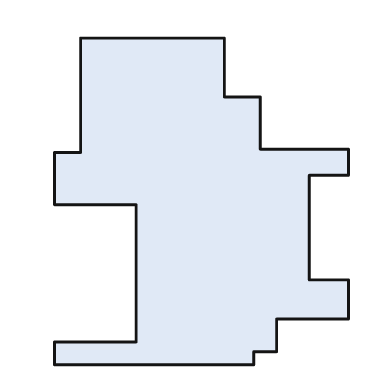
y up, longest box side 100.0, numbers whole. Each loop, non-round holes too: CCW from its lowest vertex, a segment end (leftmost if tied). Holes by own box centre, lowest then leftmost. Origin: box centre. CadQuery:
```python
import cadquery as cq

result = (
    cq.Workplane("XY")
    .moveTo(-45.0, -50.0)
    .lineTo(16.0, -50.0)
    .lineTo(16.0, -46.0)
    .lineTo(23.0, -46.0)
    .lineTo(23.0, -36.0)
    .lineTo(45.0, -36.0)
    .lineTo(45.0, -24.0)
    .lineTo(33.0, -24.0)
    .lineTo(33.0, 8.0)
    .lineTo(45.0, 8.0)
    .lineTo(45.0, 16.0)
    .lineTo(18.0, 16.0)
    .lineTo(18.0, 32.0)
    .lineTo(7.0, 32.0)
    .lineTo(7.0, 50.0)
    .lineTo(-37.0, 50.0)
    .lineTo(-37.0, 15.0)
    .lineTo(-45.0, 15.0)
    .lineTo(-45.0, -1.0)
    .lineTo(-20.0, -1.0)
    .lineTo(-20.0, -43.0)
    .lineTo(-45.0, -43.0)
    .close()
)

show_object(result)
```